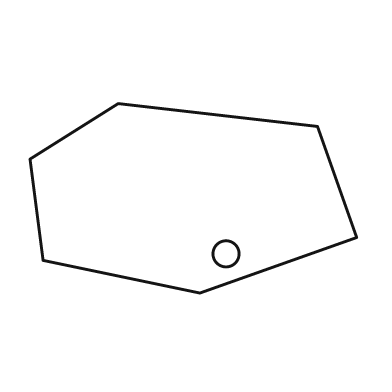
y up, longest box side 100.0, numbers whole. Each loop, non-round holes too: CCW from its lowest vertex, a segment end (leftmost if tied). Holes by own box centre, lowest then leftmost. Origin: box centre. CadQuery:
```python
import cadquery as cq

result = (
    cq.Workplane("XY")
    .moveTo(2.0, -29.0)
    .lineTo(50.0, -12.0)
    .lineTo(38.0, 22.0)
    .lineTo(-23.0, 29.0)
    .lineTo(-50.0, 12.0)
    .lineTo(-46.0, -19.0)
    .close()
    .moveTo(10.0, -17.0)
    .circle(4.0)
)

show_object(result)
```